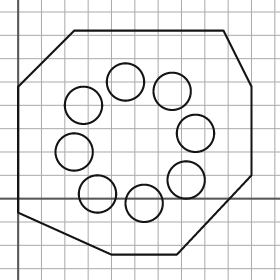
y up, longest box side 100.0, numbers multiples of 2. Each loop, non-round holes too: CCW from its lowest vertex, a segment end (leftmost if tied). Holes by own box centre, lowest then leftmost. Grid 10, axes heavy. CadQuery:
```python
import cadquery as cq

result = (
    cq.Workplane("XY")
    .moveTo(40.0, -24.0)
    .lineTo(68.0, -24.0)
    .lineTo(100.0, 10.0)
    .lineTo(100.0, 48.0)
    .lineTo(88.0, 72.0)
    .lineTo(24.0, 72.0)
    .lineTo(0.0, 48.0)
    .lineTo(0.0, -6.0)
    .close()
    .moveTo(54.0, -2.0)
    .circle(8.0)
    .moveTo(34.0, 2.0)
    .circle(8.0)
    .moveTo(72.0, 8.0)
    .circle(8.0)
    .moveTo(24.0, 20.0)
    .circle(8.0)
    .moveTo(76.0, 28.0)
    .circle(8.0)
    .moveTo(28.0, 40.0)
    .circle(8.0)
    .moveTo(66.0, 46.0)
    .circle(8.0)
    .moveTo(46.0, 50.0)
    .circle(8.0)
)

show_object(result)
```